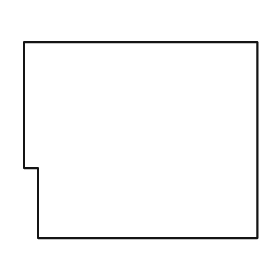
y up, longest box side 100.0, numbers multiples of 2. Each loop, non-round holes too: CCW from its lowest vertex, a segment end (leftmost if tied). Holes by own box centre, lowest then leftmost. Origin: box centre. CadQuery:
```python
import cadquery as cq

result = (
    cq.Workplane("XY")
    .moveTo(-44.0, -42.0)
    .lineTo(50.0, -42.0)
    .lineTo(50.0, 42.0)
    .lineTo(-50.0, 42.0)
    .lineTo(-50.0, -12.0)
    .lineTo(-44.0, -12.0)
    .close()
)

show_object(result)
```